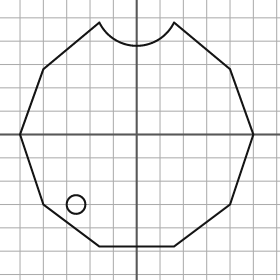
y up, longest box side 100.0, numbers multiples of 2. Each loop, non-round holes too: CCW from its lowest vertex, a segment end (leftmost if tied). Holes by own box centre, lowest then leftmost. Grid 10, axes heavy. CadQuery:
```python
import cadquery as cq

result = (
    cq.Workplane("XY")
    .moveTo(-16.0, -48.0)
    .lineTo(16.0, -48.0)
    .lineTo(40.0, -30.0)
    .lineTo(50.0, 0.0)
    .lineTo(40.0, 28.0)
    .lineTo(16.0, 48.0)
    .threePointArc((0.0, 38.0), (-16.0, 48.0))
    .lineTo(-40.0, 28.0)
    .lineTo(-50.0, 0.0)
    .lineTo(-40.0, -30.0)
    .close()
    .moveTo(-26.0, -30.0)
    .circle(4.0)
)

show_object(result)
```